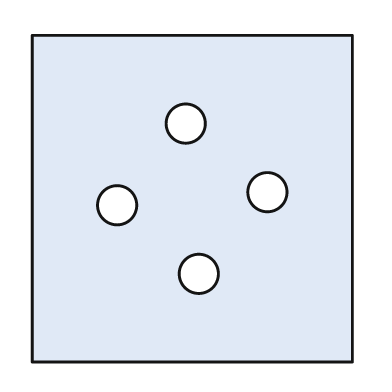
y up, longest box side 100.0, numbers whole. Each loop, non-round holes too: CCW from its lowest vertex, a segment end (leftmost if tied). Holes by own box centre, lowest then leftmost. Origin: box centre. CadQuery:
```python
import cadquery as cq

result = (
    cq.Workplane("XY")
    .moveTo(-49.0, -50.0)
    .lineTo(49.0, -50.0)
    .lineTo(49.0, 50.0)
    .lineTo(-49.0, 50.0)
    .close()
    .moveTo(2.0, -23.0)
    .circle(6.0)
    .moveTo(-23.0, -2.0)
    .circle(6.0)
    .moveTo(23.0, 2.0)
    .circle(6.0)
    .moveTo(-2.0, 23.0)
    .circle(6.0)
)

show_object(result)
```